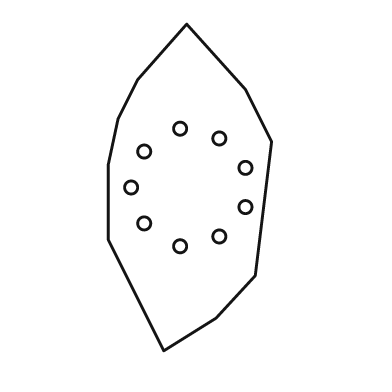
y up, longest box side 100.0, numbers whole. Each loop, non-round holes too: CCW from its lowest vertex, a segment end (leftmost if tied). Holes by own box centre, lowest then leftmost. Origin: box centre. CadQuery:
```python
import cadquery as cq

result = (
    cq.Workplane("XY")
    .moveTo(-8.0, -50.0)
    .lineTo(8.0, -40.0)
    .lineTo(20.0, -27.0)
    .lineTo(25.0, 14.0)
    .lineTo(17.0, 30.0)
    .lineTo(-1.0, 50.0)
    .lineTo(-16.0, 33.0)
    .lineTo(-22.0, 21.0)
    .lineTo(-25.0, 7.0)
    .lineTo(-25.0, -16.0)
    .close()
    .moveTo(-3.0, -18.0)
    .circle(2.0)
    .moveTo(9.0, -15.0)
    .circle(2.0)
    .moveTo(-14.0, -11.0)
    .circle(2.0)
    .moveTo(17.0, -6.0)
    .circle(2.0)
    .moveTo(-18.0, 0.0)
    .circle(2.0)
    .moveTo(17.0, 6.0)
    .circle(2.0)
    .moveTo(-14.0, 11.0)
    .circle(2.0)
    .moveTo(9.0, 15.0)
    .circle(2.0)
    .moveTo(-3.0, 18.0)
    .circle(2.0)
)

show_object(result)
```